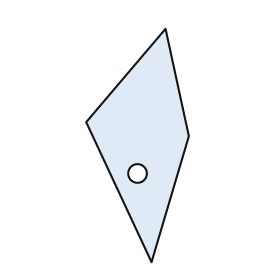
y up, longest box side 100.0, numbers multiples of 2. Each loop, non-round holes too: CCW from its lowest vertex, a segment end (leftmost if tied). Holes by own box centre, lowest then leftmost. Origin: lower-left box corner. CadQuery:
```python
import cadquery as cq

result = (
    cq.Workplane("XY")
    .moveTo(28.0, 0.0)
    .lineTo(44.0, 54.0)
    .lineTo(34.0, 100.0)
    .lineTo(0.0, 60.0)
    .close()
    .moveTo(22.0, 38.0)
    .circle(4.0)
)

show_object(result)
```